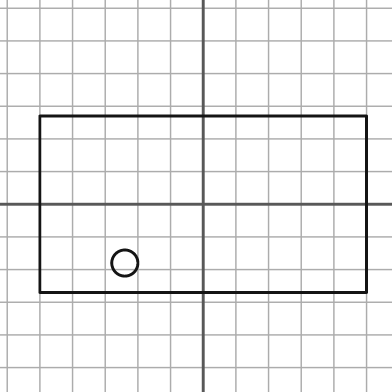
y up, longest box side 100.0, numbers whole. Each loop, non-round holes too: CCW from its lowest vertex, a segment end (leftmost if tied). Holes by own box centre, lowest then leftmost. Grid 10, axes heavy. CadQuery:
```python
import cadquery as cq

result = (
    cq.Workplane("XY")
    .moveTo(-50.0, -27.0)
    .lineTo(50.0, -27.0)
    .lineTo(50.0, 27.0)
    .lineTo(-50.0, 27.0)
    .close()
    .moveTo(-24.0, -18.0)
    .circle(4.0)
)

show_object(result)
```